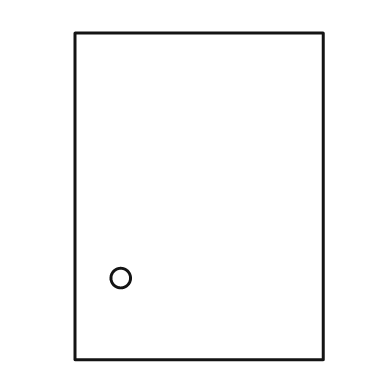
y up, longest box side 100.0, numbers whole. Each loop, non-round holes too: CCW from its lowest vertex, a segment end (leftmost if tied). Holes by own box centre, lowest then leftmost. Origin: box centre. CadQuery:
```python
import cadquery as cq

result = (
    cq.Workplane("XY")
    .moveTo(-38.0, -50.0)
    .lineTo(38.0, -50.0)
    .lineTo(38.0, 50.0)
    .lineTo(-38.0, 50.0)
    .close()
    .moveTo(-24.0, -25.0)
    .circle(3.0)
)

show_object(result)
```